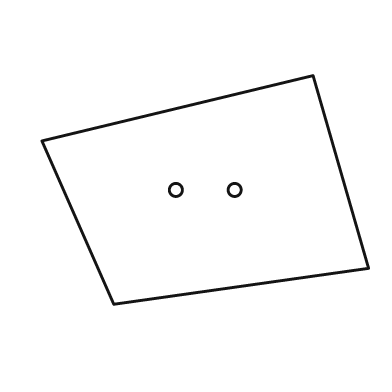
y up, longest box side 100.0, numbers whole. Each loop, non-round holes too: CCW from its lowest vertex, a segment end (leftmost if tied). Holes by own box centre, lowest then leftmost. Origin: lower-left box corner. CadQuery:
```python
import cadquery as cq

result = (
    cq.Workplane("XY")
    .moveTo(22.0, 0.0)
    .lineTo(100.0, 11.0)
    .lineTo(83.0, 70.0)
    .lineTo(0.0, 50.0)
    .close()
    .moveTo(41.0, 35.0)
    .circle(2.0)
    .moveTo(59.0, 35.0)
    .circle(2.0)
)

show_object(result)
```